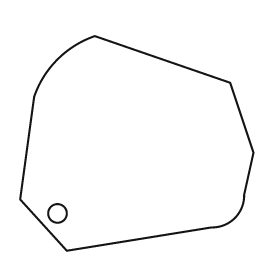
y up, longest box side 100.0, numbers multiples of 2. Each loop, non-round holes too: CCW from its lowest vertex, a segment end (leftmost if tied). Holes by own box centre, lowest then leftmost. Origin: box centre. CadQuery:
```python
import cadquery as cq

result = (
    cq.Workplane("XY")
    .moveTo(-30.0, -46.0)
    .lineTo(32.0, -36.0)
    .threePointArc((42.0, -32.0), (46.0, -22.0))
    .lineTo(50.0, -4.0)
    .lineTo(40.0, 26.0)
    .lineTo(-18.0, 46.0)
    .threePointArc((-34.0, 36.0), (-44.0, 20.0))
    .lineTo(-50.0, -24.0)
    .close()
    .moveTo(-34.0, -30.0)
    .circle(4.0)
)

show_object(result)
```